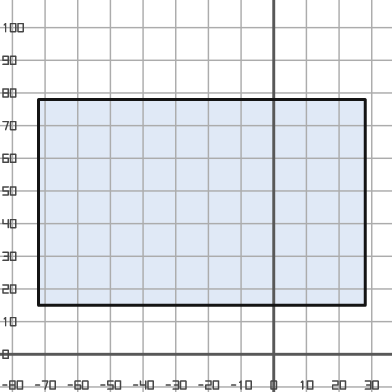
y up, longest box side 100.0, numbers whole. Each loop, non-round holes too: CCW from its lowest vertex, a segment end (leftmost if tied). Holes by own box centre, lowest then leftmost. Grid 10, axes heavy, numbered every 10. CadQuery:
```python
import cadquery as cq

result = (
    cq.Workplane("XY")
    .moveTo(-72.0, 15.0)
    .lineTo(28.0, 15.0)
    .lineTo(28.0, 78.0)
    .lineTo(-72.0, 78.0)
    .close()
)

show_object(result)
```